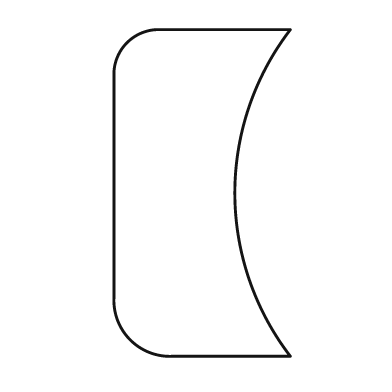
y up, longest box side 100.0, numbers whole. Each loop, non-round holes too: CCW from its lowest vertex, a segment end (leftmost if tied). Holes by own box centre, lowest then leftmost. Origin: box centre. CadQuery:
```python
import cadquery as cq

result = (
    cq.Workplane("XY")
    .moveTo(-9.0, -50.0)
    .lineTo(27.0, -50.0)
    .threePointArc((10.0, 0.0), (27.0, 50.0))
    .lineTo(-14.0, 50.0)
    .threePointArc((-23.0, 46.0), (-27.0, 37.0))
    .lineTo(-27.0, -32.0)
    .threePointArc((-22.0, -45.0), (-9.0, -50.0))
    .close()
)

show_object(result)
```